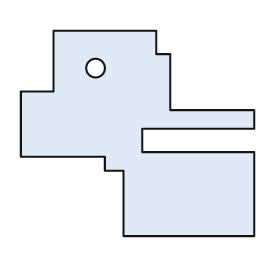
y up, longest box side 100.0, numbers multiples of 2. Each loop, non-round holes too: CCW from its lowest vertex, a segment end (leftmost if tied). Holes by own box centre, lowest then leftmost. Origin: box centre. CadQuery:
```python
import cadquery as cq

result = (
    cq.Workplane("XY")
    .moveTo(-6.0, -44.0)
    .lineTo(50.0, -44.0)
    .lineTo(50.0, -8.0)
    .lineTo(2.0, -8.0)
    .lineTo(2.0, 2.0)
    .lineTo(50.0, 2.0)
    .lineTo(50.0, 10.0)
    .lineTo(14.0, 10.0)
    .lineTo(14.0, 34.0)
    .lineTo(8.0, 34.0)
    .lineTo(8.0, 44.0)
    .lineTo(-36.0, 44.0)
    .lineTo(-36.0, 18.0)
    .lineTo(-50.0, 18.0)
    .lineTo(-50.0, -10.0)
    .lineTo(-14.0, -10.0)
    .lineTo(-14.0, -16.0)
    .lineTo(-6.0, -16.0)
    .close()
    .moveTo(-18.0, 28.0)
    .circle(4.0)
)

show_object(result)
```